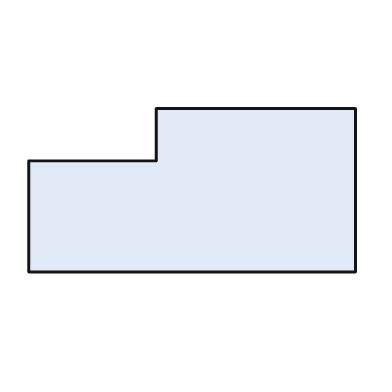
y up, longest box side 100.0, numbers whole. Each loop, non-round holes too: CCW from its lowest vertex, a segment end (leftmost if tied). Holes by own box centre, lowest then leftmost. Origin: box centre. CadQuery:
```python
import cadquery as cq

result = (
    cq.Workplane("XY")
    .moveTo(-50.0, -25.0)
    .lineTo(50.0, -25.0)
    .lineTo(50.0, 25.0)
    .lineTo(-11.0, 25.0)
    .lineTo(-11.0, 9.0)
    .lineTo(-50.0, 9.0)
    .close()
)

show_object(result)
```